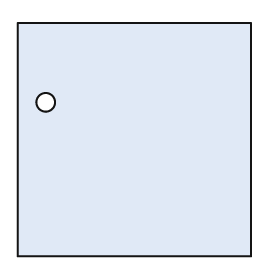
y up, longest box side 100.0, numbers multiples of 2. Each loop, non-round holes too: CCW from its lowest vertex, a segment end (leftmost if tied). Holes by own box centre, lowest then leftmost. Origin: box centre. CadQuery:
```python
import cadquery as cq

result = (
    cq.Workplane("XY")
    .moveTo(-50.0, -50.0)
    .lineTo(50.0, -50.0)
    .lineTo(50.0, 50.0)
    .lineTo(-50.0, 50.0)
    .close()
    .moveTo(-38.0, 16.0)
    .circle(4.0)
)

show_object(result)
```